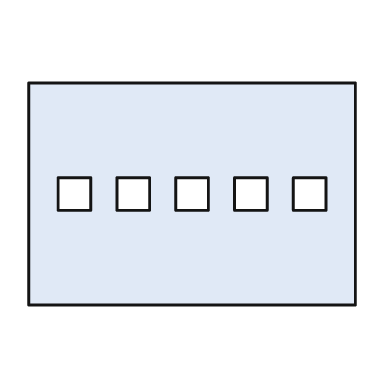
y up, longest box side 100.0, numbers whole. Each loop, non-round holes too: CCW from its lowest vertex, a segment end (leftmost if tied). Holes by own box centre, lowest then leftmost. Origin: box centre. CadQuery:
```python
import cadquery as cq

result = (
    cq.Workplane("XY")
    .moveTo(-50.0, -34.0)
    .lineTo(50.0, -34.0)
    .lineTo(50.0, 34.0)
    .lineTo(-50.0, 34.0)
    .close()
    .moveTo(-41.0, -5.0)
    .lineTo(-31.0, -5.0)
    .lineTo(-31.0, 5.0)
    .lineTo(-41.0, 5.0)
    .close()
    .moveTo(-23.0, -5.0)
    .lineTo(-13.0, -5.0)
    .lineTo(-13.0, 5.0)
    .lineTo(-23.0, 5.0)
    .close()
    .moveTo(-5.0, -5.0)
    .lineTo(5.0, -5.0)
    .lineTo(5.0, 5.0)
    .lineTo(-5.0, 5.0)
    .close()
    .moveTo(13.0, -5.0)
    .lineTo(23.0, -5.0)
    .lineTo(23.0, 5.0)
    .lineTo(13.0, 5.0)
    .close()
    .moveTo(31.0, -5.0)
    .lineTo(41.0, -5.0)
    .lineTo(41.0, 5.0)
    .lineTo(31.0, 5.0)
    .close()
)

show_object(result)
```